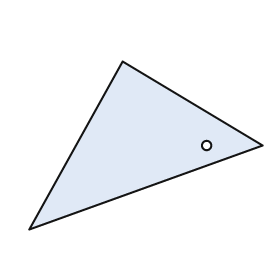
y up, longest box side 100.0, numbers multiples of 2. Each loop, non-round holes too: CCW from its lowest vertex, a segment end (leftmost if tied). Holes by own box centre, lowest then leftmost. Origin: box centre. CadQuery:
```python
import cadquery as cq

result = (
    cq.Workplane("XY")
    .moveTo(-50.0, -36.0)
    .lineTo(50.0, 0.0)
    .lineTo(-10.0, 36.0)
    .close()
    .moveTo(26.0, 0.0)
    .circle(2.0)
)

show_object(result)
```